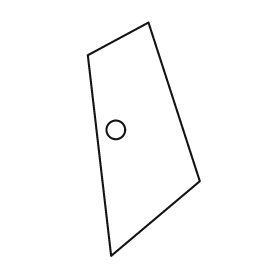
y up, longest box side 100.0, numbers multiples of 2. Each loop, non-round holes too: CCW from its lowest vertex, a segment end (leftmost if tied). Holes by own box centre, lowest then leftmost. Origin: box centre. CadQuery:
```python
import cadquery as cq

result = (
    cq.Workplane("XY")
    .moveTo(-14.0, -50.0)
    .lineTo(24.0, -18.0)
    .lineTo(2.0, 50.0)
    .lineTo(-24.0, 36.0)
    .close()
    .moveTo(-12.0, 4.0)
    .circle(4.0)
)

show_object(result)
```